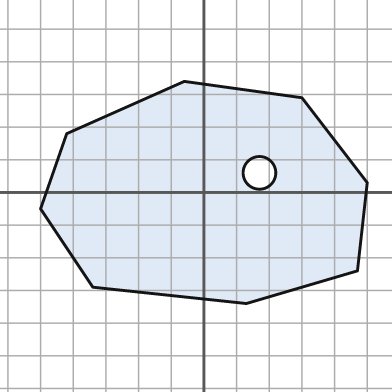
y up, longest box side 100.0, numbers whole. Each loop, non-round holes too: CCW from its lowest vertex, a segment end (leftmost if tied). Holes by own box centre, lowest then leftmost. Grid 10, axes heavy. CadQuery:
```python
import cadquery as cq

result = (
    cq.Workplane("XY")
    .moveTo(13.0, -34.0)
    .lineTo(47.0, -24.0)
    .lineTo(50.0, 3.0)
    .lineTo(30.0, 29.0)
    .lineTo(-6.0, 34.0)
    .lineTo(-42.0, 18.0)
    .lineTo(-50.0, -5.0)
    .lineTo(-34.0, -29.0)
    .close()
    .moveTo(17.0, 6.0)
    .circle(5.0)
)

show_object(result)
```